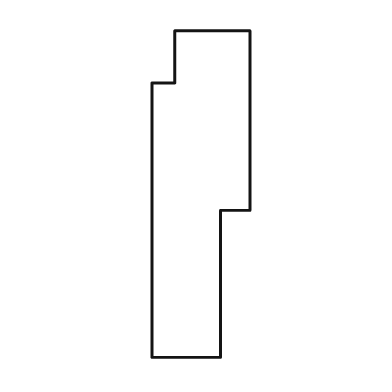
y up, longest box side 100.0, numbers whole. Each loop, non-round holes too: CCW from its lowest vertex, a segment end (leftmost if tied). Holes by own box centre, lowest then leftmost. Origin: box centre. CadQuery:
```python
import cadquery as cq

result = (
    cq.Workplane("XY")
    .moveTo(-15.0, -50.0)
    .lineTo(6.0, -50.0)
    .lineTo(6.0, -5.0)
    .lineTo(15.0, -5.0)
    .lineTo(15.0, 50.0)
    .lineTo(-8.0, 50.0)
    .lineTo(-8.0, 34.0)
    .lineTo(-15.0, 34.0)
    .close()
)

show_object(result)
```